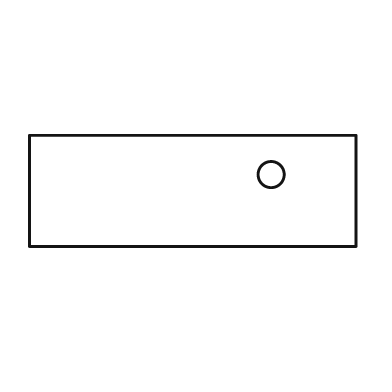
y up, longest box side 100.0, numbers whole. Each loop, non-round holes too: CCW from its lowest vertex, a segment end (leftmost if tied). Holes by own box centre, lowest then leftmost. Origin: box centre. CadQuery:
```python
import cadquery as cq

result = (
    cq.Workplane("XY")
    .moveTo(-50.0, -17.0)
    .lineTo(50.0, -17.0)
    .lineTo(50.0, 17.0)
    .lineTo(-50.0, 17.0)
    .close()
    .moveTo(24.0, 5.0)
    .circle(4.0)
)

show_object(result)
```